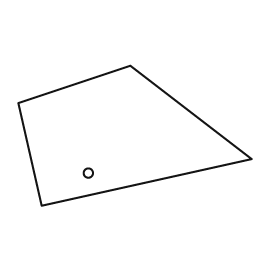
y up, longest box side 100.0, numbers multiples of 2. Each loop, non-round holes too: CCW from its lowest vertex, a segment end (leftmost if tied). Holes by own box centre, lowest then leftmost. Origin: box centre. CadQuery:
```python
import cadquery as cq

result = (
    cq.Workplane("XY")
    .moveTo(-40.0, -30.0)
    .lineTo(50.0, -10.0)
    .lineTo(-2.0, 30.0)
    .lineTo(-50.0, 14.0)
    .close()
    .moveTo(-20.0, -16.0)
    .circle(2.0)
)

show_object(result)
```